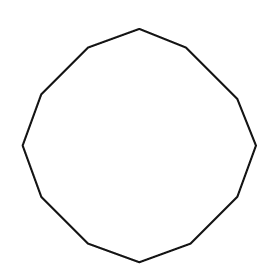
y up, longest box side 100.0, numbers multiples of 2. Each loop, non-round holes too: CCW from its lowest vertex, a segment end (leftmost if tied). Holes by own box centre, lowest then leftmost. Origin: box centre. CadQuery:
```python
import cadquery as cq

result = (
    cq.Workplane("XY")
    .moveTo(0.0, -50.0)
    .lineTo(22.0, -42.0)
    .lineTo(42.0, -22.0)
    .lineTo(50.0, 0.0)
    .lineTo(42.0, 20.0)
    .lineTo(20.0, 42.0)
    .lineTo(0.0, 50.0)
    .lineTo(-22.0, 42.0)
    .lineTo(-42.0, 22.0)
    .lineTo(-50.0, 0.0)
    .lineTo(-42.0, -22.0)
    .lineTo(-22.0, -42.0)
    .close()
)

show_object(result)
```